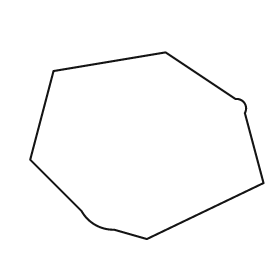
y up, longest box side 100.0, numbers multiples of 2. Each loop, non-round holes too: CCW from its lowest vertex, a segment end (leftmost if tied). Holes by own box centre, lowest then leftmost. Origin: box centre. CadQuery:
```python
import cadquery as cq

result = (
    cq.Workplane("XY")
    .moveTo(0.0, -40.0)
    .lineTo(50.0, -16.0)
    .lineTo(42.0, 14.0)
    .threePointArc((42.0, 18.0), (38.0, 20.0))
    .lineTo(8.0, 40.0)
    .lineTo(-40.0, 32.0)
    .lineTo(-50.0, -6.0)
    .lineTo(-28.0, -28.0)
    .threePointArc((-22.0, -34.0), (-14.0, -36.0))
    .close()
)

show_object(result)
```